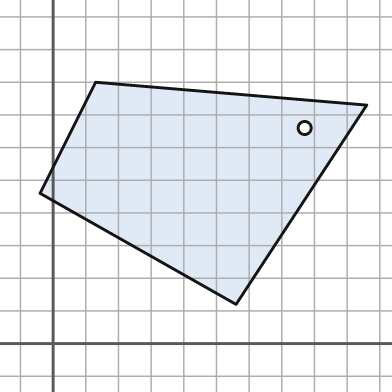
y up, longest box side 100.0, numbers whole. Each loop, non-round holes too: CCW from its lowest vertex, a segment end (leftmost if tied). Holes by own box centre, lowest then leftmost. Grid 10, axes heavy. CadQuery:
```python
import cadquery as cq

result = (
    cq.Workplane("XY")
    .moveTo(56.0, 12.0)
    .lineTo(96.0, 73.0)
    .lineTo(13.0, 80.0)
    .lineTo(-4.0, 46.0)
    .close()
    .moveTo(77.0, 66.0)
    .circle(2.0)
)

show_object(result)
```